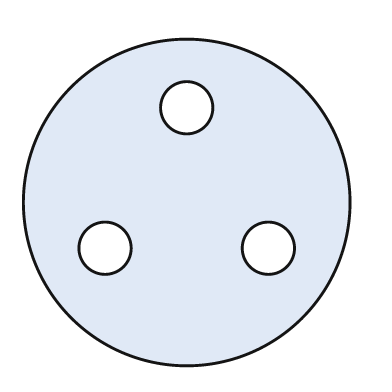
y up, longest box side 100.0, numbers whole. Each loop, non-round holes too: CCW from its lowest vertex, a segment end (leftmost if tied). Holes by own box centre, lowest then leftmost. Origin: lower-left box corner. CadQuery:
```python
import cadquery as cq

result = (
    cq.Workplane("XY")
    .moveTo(50.0, 50.0)
    .circle(50.0)
    .moveTo(25.0, 36.0)
    .circle(8.0)
    .moveTo(75.0, 36.0)
    .circle(8.0)
    .moveTo(50.0, 79.0)
    .circle(8.0)
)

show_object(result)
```